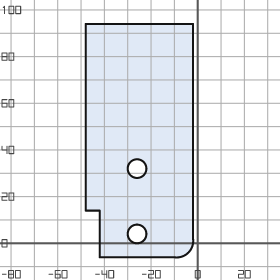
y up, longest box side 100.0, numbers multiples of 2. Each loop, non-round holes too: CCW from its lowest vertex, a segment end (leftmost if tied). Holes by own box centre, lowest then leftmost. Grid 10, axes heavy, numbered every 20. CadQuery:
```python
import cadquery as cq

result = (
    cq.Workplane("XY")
    .moveTo(-42.0, -6.0)
    .lineTo(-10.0, -6.0)
    .threePointArc((-4.0, -4.0), (-2.0, 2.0))
    .lineTo(-2.0, 94.0)
    .lineTo(-48.0, 94.0)
    .lineTo(-48.0, 14.0)
    .lineTo(-42.0, 14.0)
    .close()
    .moveTo(-26.0, 4.0)
    .circle(4.0)
    .moveTo(-26.0, 32.0)
    .circle(4.0)
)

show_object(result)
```